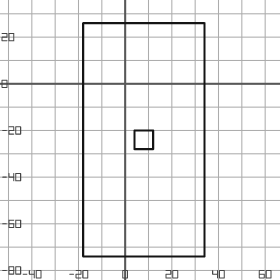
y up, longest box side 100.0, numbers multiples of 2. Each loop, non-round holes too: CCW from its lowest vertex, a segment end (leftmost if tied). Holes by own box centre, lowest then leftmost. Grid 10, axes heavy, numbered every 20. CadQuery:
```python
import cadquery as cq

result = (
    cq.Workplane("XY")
    .moveTo(-18.0, -74.0)
    .lineTo(34.0, -74.0)
    .lineTo(34.0, 26.0)
    .lineTo(-18.0, 26.0)
    .close()
    .moveTo(4.0, -28.0)
    .lineTo(12.0, -28.0)
    .lineTo(12.0, -20.0)
    .lineTo(4.0, -20.0)
    .close()
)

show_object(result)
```